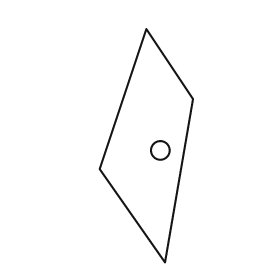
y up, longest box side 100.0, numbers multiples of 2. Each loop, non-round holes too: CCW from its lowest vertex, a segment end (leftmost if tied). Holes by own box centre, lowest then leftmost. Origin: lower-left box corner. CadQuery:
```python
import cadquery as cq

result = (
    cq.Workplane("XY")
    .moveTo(28.0, 0.0)
    .lineTo(40.0, 70.0)
    .lineTo(20.0, 100.0)
    .lineTo(0.0, 40.0)
    .close()
    .moveTo(26.0, 48.0)
    .circle(4.0)
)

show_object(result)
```